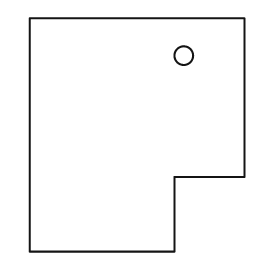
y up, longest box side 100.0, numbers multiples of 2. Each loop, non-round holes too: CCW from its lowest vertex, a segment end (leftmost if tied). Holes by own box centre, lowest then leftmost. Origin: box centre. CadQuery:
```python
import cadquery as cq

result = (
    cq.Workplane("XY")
    .moveTo(-46.0, -50.0)
    .lineTo(16.0, -50.0)
    .lineTo(16.0, -18.0)
    .lineTo(46.0, -18.0)
    .lineTo(46.0, 50.0)
    .lineTo(-46.0, 50.0)
    .close()
    .moveTo(20.0, 34.0)
    .circle(4.0)
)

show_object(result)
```